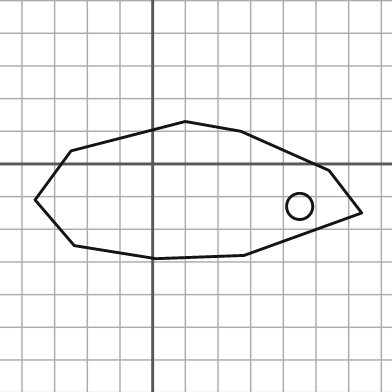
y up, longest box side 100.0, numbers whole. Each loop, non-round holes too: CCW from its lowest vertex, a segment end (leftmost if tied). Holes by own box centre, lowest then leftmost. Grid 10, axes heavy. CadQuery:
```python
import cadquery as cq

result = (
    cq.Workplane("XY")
    .moveTo(1.0, -29.0)
    .lineTo(28.0, -28.0)
    .lineTo(64.0, -15.0)
    .lineTo(54.0, -2.0)
    .lineTo(27.0, 10.0)
    .lineTo(10.0, 13.0)
    .lineTo(-25.0, 4.0)
    .lineTo(-36.0, -11.0)
    .lineTo(-24.0, -25.0)
    .close()
    .moveTo(45.0, -13.0)
    .circle(4.0)
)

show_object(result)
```